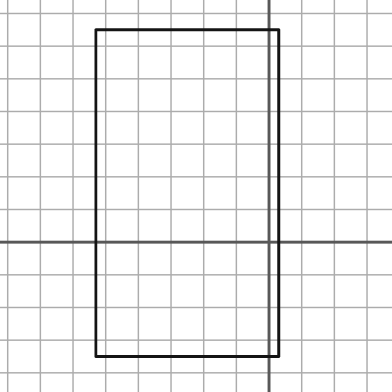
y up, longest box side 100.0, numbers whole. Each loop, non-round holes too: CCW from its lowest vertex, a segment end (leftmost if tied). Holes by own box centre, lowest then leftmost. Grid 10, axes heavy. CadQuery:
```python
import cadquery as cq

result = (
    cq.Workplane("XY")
    .moveTo(-53.0, -35.0)
    .lineTo(3.0, -35.0)
    .lineTo(3.0, 65.0)
    .lineTo(-53.0, 65.0)
    .close()
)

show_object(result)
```